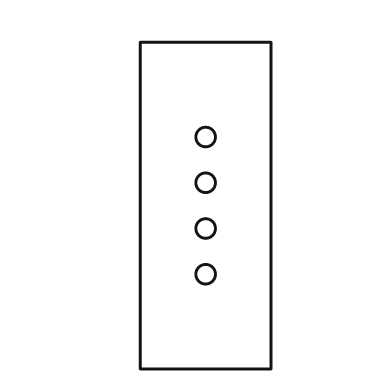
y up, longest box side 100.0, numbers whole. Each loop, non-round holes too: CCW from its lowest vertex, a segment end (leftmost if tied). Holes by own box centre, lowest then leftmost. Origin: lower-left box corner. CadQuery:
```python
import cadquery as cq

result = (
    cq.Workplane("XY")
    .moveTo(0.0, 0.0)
    .lineTo(40.0, 0.0)
    .lineTo(40.0, 100.0)
    .lineTo(0.0, 100.0)
    .close()
    .moveTo(20.0, 29.0)
    .circle(3.0)
    .moveTo(20.0, 43.0)
    .circle(3.0)
    .moveTo(20.0, 57.0)
    .circle(3.0)
    .moveTo(20.0, 71.0)
    .circle(3.0)
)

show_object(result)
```